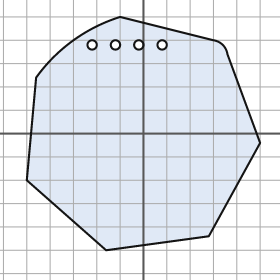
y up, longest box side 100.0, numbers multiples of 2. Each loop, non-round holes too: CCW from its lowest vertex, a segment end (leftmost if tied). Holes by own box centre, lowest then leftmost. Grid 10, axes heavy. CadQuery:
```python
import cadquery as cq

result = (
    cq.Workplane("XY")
    .moveTo(-16.0, -50.0)
    .lineTo(28.0, -44.0)
    .lineTo(50.0, -4.0)
    .lineTo(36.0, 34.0)
    .threePointArc((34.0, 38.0), (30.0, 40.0))
    .lineTo(-10.0, 50.0)
    .threePointArc((-30.0, 40.0), (-46.0, 24.0))
    .lineTo(-50.0, -20.0)
    .close()
    .moveTo(-22.0, 38.0)
    .circle(2.0)
    .moveTo(-12.0, 38.0)
    .circle(2.0)
    .moveTo(-2.0, 38.0)
    .circle(2.0)
    .moveTo(8.0, 38.0)
    .circle(2.0)
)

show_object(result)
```